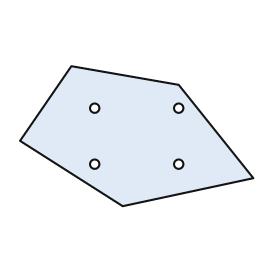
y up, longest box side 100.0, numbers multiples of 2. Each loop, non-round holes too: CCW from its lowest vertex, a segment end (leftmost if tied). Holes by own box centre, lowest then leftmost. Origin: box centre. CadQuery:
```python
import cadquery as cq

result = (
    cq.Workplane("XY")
    .moveTo(-6.0, -30.0)
    .lineTo(50.0, -18.0)
    .lineTo(18.0, 22.0)
    .lineTo(-28.0, 30.0)
    .lineTo(-50.0, -2.0)
    .close()
    .moveTo(-18.0, -12.0)
    .circle(2.0)
    .moveTo(18.0, -12.0)
    .circle(2.0)
    .moveTo(-18.0, 12.0)
    .circle(2.0)
    .moveTo(18.0, 12.0)
    .circle(2.0)
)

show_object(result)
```